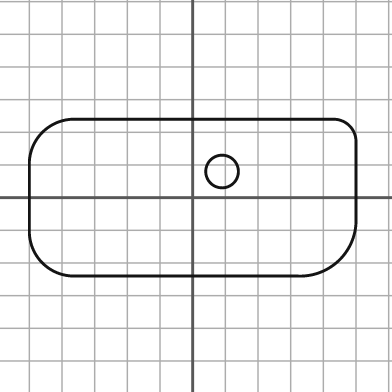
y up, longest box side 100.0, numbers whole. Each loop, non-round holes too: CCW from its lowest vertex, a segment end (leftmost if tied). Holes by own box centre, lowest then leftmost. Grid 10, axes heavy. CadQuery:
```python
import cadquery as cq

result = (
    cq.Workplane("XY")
    .moveTo(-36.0, -24.0)
    .lineTo(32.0, -24.0)
    .threePointArc((45.0, -19.0), (50.0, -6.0))
    .lineTo(50.0, 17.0)
    .threePointArc((48.0, 22.0), (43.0, 24.0))
    .lineTo(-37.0, 24.0)
    .threePointArc((-46.0, 20.0), (-50.0, 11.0))
    .lineTo(-50.0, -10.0)
    .threePointArc((-46.0, -20.0), (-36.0, -24.0))
    .close()
    .moveTo(9.0, 8.0)
    .circle(5.0)
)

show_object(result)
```